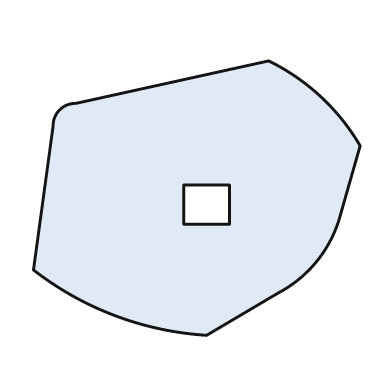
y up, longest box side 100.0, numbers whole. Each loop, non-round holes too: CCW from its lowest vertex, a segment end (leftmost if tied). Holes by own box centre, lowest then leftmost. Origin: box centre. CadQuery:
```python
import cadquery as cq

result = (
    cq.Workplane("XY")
    .moveTo(3.0, -42.0)
    .lineTo(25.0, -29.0)
    .threePointArc((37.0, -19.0), (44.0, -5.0))
    .lineTo(50.0, 16.0)
    .threePointArc((38.0, 31.0), (22.0, 42.0))
    .lineTo(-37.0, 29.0)
    .threePointArc((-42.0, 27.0), (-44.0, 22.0))
    .lineTo(-50.0, -22.0)
    .threePointArc((-25.0, -36.0), (3.0, -42.0))
    .close()
    .moveTo(-4.0, -8.0)
    .lineTo(10.0, -8.0)
    .lineTo(10.0, 4.0)
    .lineTo(-4.0, 4.0)
    .close()
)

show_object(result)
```